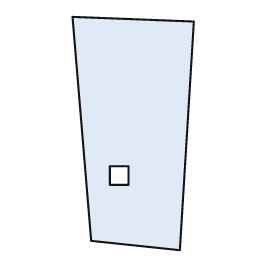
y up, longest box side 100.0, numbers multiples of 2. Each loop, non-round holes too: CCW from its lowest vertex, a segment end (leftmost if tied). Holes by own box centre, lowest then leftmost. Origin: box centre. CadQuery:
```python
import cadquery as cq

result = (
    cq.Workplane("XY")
    .moveTo(20.0, -50.0)
    .lineTo(26.0, 48.0)
    .lineTo(-26.0, 50.0)
    .lineTo(-18.0, -46.0)
    .close()
    .moveTo(-10.0, -22.0)
    .lineTo(-2.0, -22.0)
    .lineTo(-2.0, -14.0)
    .lineTo(-10.0, -14.0)
    .close()
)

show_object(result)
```